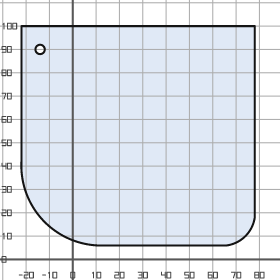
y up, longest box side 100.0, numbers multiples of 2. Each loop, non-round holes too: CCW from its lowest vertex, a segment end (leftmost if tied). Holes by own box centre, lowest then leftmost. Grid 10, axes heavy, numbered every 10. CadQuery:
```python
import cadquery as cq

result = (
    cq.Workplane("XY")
    .moveTo(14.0, 6.0)
    .lineTo(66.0, 6.0)
    .threePointArc((74.0, 10.0), (78.0, 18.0))
    .lineTo(78.0, 100.0)
    .lineTo(-22.0, 100.0)
    .lineTo(-22.0, 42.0)
    .threePointArc((-12.0, 16.0), (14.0, 6.0))
    .close()
    .moveTo(-14.0, 90.0)
    .circle(2.0)
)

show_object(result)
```